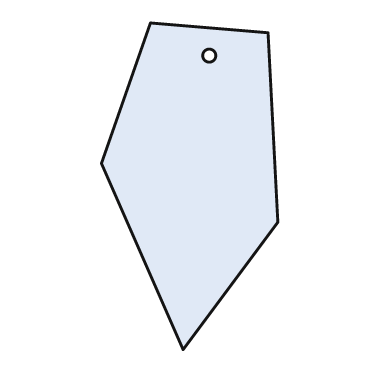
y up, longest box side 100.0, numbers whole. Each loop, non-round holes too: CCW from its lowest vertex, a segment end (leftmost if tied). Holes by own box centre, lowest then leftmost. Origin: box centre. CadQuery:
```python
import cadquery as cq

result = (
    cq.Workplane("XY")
    .moveTo(-2.0, -50.0)
    .lineTo(27.0, -11.0)
    .lineTo(24.0, 47.0)
    .lineTo(-12.0, 50.0)
    .lineTo(-27.0, 7.0)
    .close()
    .moveTo(6.0, 40.0)
    .circle(2.0)
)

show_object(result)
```